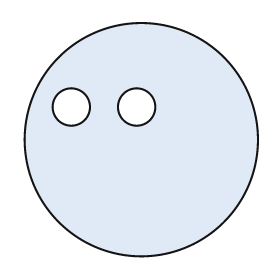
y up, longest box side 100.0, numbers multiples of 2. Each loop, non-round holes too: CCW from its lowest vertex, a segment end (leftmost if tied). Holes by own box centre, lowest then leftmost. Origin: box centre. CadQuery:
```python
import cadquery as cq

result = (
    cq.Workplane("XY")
    .moveTo(0.0, 0.0)
    .circle(50.0)
    .moveTo(-30.0, 14.0)
    .circle(8.0)
    .moveTo(-2.0, 14.0)
    .circle(8.0)
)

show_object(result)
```